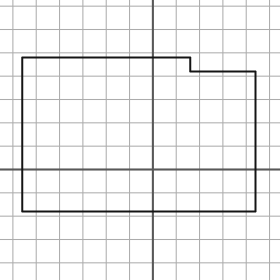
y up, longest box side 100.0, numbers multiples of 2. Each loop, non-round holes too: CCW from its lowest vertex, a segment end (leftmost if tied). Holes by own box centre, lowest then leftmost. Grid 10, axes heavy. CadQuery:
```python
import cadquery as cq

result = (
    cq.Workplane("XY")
    .moveTo(-56.0, -18.0)
    .lineTo(44.0, -18.0)
    .lineTo(44.0, 42.0)
    .lineTo(16.0, 42.0)
    .lineTo(16.0, 48.0)
    .lineTo(-56.0, 48.0)
    .close()
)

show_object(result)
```